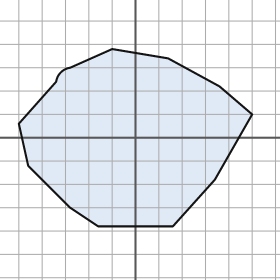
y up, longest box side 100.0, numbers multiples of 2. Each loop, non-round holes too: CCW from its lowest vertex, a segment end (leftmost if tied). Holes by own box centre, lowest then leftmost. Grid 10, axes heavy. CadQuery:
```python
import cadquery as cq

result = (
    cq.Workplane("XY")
    .moveTo(-16.0, -38.0)
    .lineTo(16.0, -38.0)
    .lineTo(34.0, -18.0)
    .lineTo(50.0, 10.0)
    .lineTo(36.0, 22.0)
    .lineTo(14.0, 34.0)
    .lineTo(-10.0, 38.0)
    .lineTo(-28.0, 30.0)
    .threePointArc((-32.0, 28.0), (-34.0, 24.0))
    .lineTo(-50.0, 6.0)
    .lineTo(-46.0, -12.0)
    .lineTo(-28.0, -30.0)
    .close()
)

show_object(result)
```